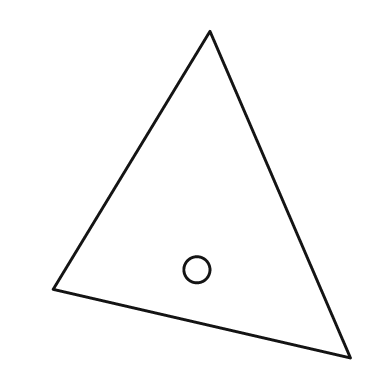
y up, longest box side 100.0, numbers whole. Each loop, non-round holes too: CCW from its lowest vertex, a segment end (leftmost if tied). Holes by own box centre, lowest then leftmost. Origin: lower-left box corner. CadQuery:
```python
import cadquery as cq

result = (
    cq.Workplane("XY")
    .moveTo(91.0, 0.0)
    .lineTo(48.0, 100.0)
    .lineTo(0.0, 21.0)
    .close()
    .moveTo(44.0, 27.0)
    .circle(4.0)
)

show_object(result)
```